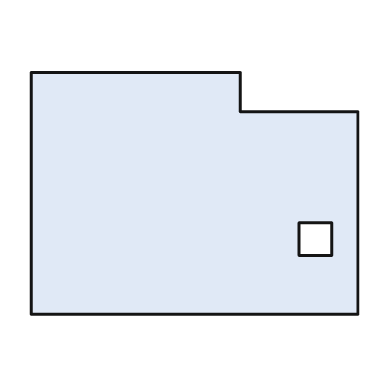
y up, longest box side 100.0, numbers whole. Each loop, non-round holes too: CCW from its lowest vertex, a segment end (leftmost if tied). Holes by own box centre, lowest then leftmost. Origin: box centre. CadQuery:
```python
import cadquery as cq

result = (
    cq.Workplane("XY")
    .moveTo(-50.0, -37.0)
    .lineTo(50.0, -37.0)
    .lineTo(50.0, 25.0)
    .lineTo(14.0, 25.0)
    .lineTo(14.0, 37.0)
    .lineTo(-50.0, 37.0)
    .close()
    .moveTo(32.0, -19.0)
    .lineTo(42.0, -19.0)
    .lineTo(42.0, -9.0)
    .lineTo(32.0, -9.0)
    .close()
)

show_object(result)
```